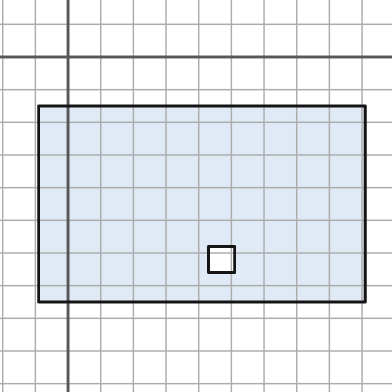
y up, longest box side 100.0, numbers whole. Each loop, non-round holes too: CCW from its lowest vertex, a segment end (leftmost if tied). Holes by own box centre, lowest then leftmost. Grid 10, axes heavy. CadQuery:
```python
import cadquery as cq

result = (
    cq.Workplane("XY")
    .moveTo(-9.0, -75.0)
    .lineTo(91.0, -75.0)
    .lineTo(91.0, -15.0)
    .lineTo(-9.0, -15.0)
    .close()
    .moveTo(43.0, -66.0)
    .lineTo(51.0, -66.0)
    .lineTo(51.0, -58.0)
    .lineTo(43.0, -58.0)
    .close()
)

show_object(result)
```